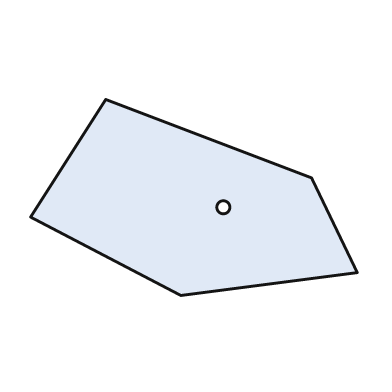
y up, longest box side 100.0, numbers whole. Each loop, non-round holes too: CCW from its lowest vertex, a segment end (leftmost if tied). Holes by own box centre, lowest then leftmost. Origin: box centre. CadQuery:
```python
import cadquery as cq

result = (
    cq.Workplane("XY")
    .moveTo(-4.0, -30.0)
    .lineTo(50.0, -23.0)
    .lineTo(36.0, 6.0)
    .lineTo(-27.0, 30.0)
    .lineTo(-50.0, -6.0)
    .close()
    .moveTo(9.0, -3.0)
    .circle(2.0)
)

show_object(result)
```